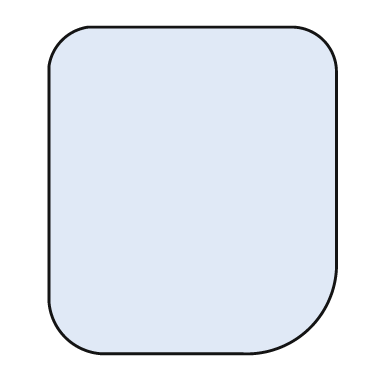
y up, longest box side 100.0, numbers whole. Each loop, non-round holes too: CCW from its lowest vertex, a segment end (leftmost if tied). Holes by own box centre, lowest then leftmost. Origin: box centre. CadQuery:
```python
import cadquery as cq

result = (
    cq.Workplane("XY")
    .moveTo(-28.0, -50.0)
    .lineTo(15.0, -50.0)
    .threePointArc((36.0, -42.0), (44.0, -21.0))
    .lineTo(44.0, 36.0)
    .threePointArc((40.0, 46.0), (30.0, 50.0))
    .lineTo(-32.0, 50.0)
    .threePointArc((-40.0, 46.0), (-44.0, 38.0))
    .lineTo(-44.0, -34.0)
    .threePointArc((-39.0, -45.0), (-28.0, -50.0))
    .close()
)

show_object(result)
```